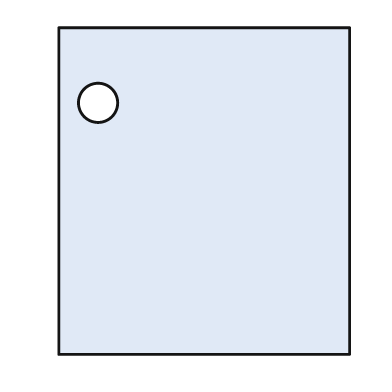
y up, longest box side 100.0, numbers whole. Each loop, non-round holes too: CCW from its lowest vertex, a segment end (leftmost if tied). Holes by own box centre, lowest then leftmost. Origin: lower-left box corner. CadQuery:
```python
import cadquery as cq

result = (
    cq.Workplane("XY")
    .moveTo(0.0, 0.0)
    .lineTo(89.0, 0.0)
    .lineTo(89.0, 100.0)
    .lineTo(0.0, 100.0)
    .close()
    .moveTo(12.0, 77.0)
    .circle(6.0)
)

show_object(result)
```